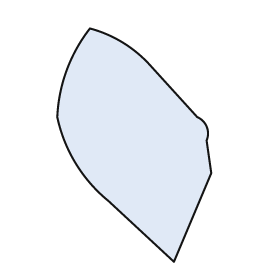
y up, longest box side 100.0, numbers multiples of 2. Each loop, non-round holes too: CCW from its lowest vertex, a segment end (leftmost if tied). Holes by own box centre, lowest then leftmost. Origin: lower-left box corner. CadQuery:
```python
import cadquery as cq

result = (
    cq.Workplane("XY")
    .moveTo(50.0, 0.0)
    .lineTo(66.0, 38.0)
    .lineTo(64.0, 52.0)
    .threePointArc((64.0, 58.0), (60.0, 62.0))
    .lineTo(40.0, 84.0)
    .threePointArc((28.0, 94.0), (14.0, 100.0))
    .threePointArc((4.0, 82.0), (0.0, 62.0))
    .threePointArc((8.0, 42.0), (22.0, 26.0))
    .close()
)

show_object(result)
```